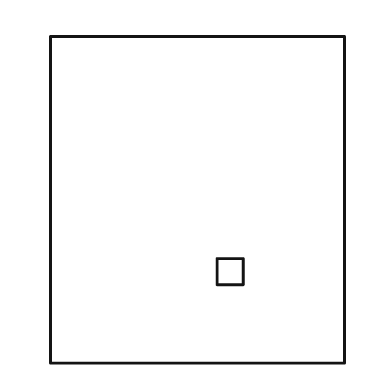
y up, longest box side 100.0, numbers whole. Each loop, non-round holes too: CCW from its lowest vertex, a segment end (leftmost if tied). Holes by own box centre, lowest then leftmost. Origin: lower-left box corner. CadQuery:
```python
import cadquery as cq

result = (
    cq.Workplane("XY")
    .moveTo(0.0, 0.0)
    .lineTo(90.0, 0.0)
    .lineTo(90.0, 100.0)
    .lineTo(0.0, 100.0)
    .close()
    .moveTo(51.0, 24.0)
    .lineTo(59.0, 24.0)
    .lineTo(59.0, 32.0)
    .lineTo(51.0, 32.0)
    .close()
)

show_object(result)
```